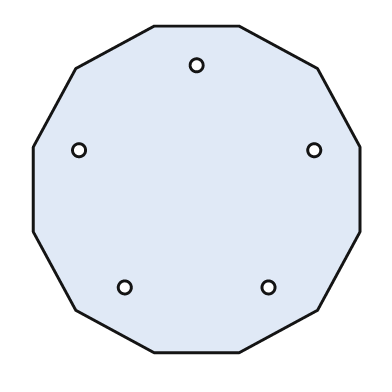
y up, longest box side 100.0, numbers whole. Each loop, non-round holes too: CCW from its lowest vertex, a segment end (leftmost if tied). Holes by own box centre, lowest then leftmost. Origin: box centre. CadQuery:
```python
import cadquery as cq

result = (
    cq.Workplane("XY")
    .moveTo(-13.0, -50.0)
    .lineTo(13.0, -50.0)
    .lineTo(37.0, -37.0)
    .lineTo(50.0, -13.0)
    .lineTo(50.0, 13.0)
    .lineTo(37.0, 37.0)
    .lineTo(13.0, 50.0)
    .lineTo(-13.0, 50.0)
    .lineTo(-37.0, 37.0)
    .lineTo(-50.0, 13.0)
    .lineTo(-50.0, -13.0)
    .lineTo(-37.0, -37.0)
    .close()
    .moveTo(-22.0, -30.0)
    .circle(2.0)
    .moveTo(22.0, -30.0)
    .circle(2.0)
    .moveTo(-36.0, 12.0)
    .circle(2.0)
    .moveTo(36.0, 12.0)
    .circle(2.0)
    .moveTo(0.0, 38.0)
    .circle(2.0)
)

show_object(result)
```